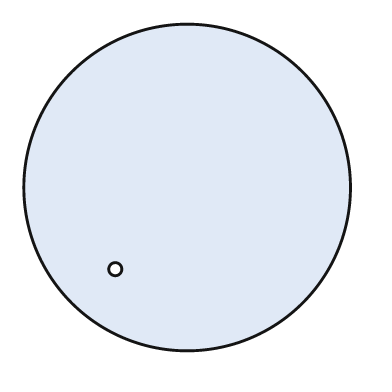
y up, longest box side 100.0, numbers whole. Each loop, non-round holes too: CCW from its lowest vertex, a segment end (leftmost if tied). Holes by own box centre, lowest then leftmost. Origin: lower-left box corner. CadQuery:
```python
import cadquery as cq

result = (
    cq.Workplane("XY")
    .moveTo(50.0, 50.0)
    .circle(50.0)
    .moveTo(28.0, 25.0)
    .circle(2.0)
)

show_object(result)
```